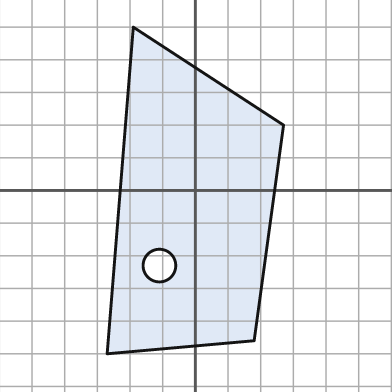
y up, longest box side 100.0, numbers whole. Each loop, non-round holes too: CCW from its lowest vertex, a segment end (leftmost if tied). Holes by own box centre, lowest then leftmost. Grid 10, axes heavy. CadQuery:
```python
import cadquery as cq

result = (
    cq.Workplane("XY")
    .moveTo(-27.0, -50.0)
    .lineTo(18.0, -46.0)
    .lineTo(27.0, 20.0)
    .lineTo(-19.0, 50.0)
    .close()
    .moveTo(-11.0, -23.0)
    .circle(5.0)
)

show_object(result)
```